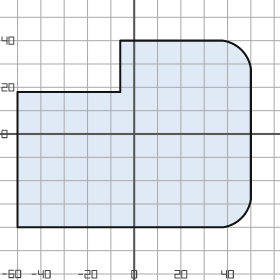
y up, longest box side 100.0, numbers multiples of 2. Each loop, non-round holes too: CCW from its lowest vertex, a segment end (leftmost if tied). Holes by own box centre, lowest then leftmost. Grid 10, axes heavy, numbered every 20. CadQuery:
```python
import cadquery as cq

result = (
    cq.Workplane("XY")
    .moveTo(-50.0, -40.0)
    .lineTo(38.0, -40.0)
    .threePointArc((46.0, -36.0), (50.0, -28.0))
    .lineTo(50.0, 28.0)
    .threePointArc((46.0, 36.0), (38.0, 40.0))
    .lineTo(-6.0, 40.0)
    .lineTo(-6.0, 18.0)
    .lineTo(-50.0, 18.0)
    .close()
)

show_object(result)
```